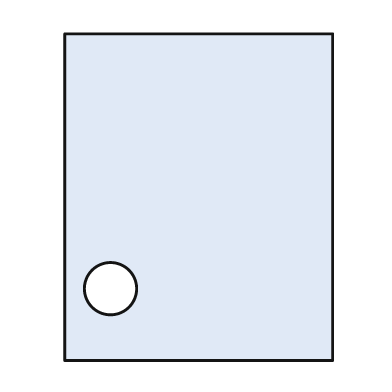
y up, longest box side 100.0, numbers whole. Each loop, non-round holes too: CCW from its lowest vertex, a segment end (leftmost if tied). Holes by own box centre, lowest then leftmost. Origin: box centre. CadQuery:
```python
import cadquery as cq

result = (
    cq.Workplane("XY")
    .moveTo(-41.0, -50.0)
    .lineTo(41.0, -50.0)
    .lineTo(41.0, 50.0)
    .lineTo(-41.0, 50.0)
    .close()
    .moveTo(-27.0, -28.0)
    .circle(8.0)
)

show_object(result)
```